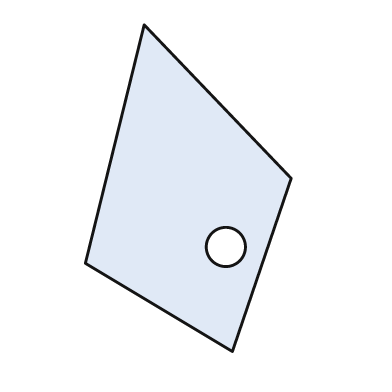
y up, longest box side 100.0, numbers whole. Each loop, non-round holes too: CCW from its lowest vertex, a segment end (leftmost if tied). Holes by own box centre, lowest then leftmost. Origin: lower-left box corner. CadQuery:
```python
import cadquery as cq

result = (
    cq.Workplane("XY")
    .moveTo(45.0, 0.0)
    .lineTo(63.0, 53.0)
    .lineTo(18.0, 100.0)
    .lineTo(0.0, 27.0)
    .close()
    .moveTo(43.0, 32.0)
    .circle(6.0)
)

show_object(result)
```